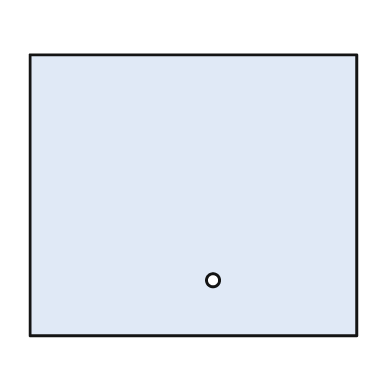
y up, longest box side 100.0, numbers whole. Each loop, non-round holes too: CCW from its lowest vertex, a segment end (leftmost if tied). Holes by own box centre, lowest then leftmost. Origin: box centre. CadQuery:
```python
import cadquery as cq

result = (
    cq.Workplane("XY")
    .moveTo(-50.0, -43.0)
    .lineTo(50.0, -43.0)
    .lineTo(50.0, 43.0)
    .lineTo(-50.0, 43.0)
    .close()
    .moveTo(6.0, -26.0)
    .circle(2.0)
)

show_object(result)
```